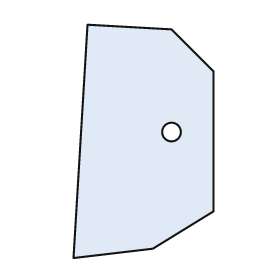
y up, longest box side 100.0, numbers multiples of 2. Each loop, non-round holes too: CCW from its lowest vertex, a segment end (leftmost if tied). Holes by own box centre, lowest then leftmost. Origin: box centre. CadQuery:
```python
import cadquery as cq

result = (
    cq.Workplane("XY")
    .moveTo(-30.0, -50.0)
    .lineTo(4.0, -46.0)
    .lineTo(30.0, -30.0)
    .lineTo(30.0, 30.0)
    .lineTo(12.0, 48.0)
    .lineTo(-24.0, 50.0)
    .close()
    .moveTo(12.0, 4.0)
    .circle(4.0)
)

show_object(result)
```